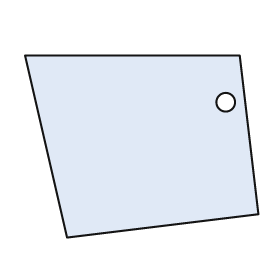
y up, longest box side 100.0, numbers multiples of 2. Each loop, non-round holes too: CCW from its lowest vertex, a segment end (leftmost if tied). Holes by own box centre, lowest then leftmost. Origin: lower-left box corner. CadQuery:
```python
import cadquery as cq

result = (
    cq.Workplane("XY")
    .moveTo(18.0, 0.0)
    .lineTo(100.0, 10.0)
    .lineTo(92.0, 78.0)
    .lineTo(0.0, 78.0)
    .close()
    .moveTo(86.0, 58.0)
    .circle(4.0)
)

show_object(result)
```